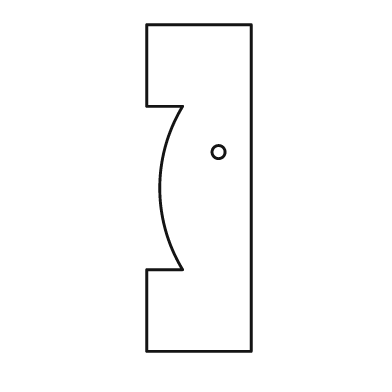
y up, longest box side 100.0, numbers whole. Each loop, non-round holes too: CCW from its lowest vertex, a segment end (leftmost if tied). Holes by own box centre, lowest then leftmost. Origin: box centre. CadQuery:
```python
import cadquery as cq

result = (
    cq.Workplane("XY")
    .moveTo(-16.0, -50.0)
    .lineTo(16.0, -50.0)
    .lineTo(16.0, 50.0)
    .lineTo(-16.0, 50.0)
    .lineTo(-16.0, 25.0)
    .lineTo(-5.0, 25.0)
    .threePointArc((-12.0, 0.0), (-5.0, -25.0))
    .lineTo(-16.0, -25.0)
    .close()
    .moveTo(6.0, 11.0)
    .circle(2.0)
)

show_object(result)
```